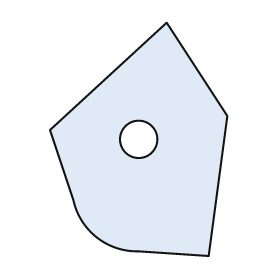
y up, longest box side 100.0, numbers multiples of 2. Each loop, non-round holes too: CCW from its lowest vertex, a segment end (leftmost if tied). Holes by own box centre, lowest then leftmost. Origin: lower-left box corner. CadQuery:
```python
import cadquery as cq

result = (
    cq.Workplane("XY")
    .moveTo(68.0, 0.0)
    .lineTo(76.0, 60.0)
    .lineTo(50.0, 100.0)
    .lineTo(0.0, 54.0)
    .lineTo(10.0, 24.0)
    .threePointArc((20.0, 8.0), (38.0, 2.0))
    .close()
    .moveTo(38.0, 50.0)
    .circle(8.0)
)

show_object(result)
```